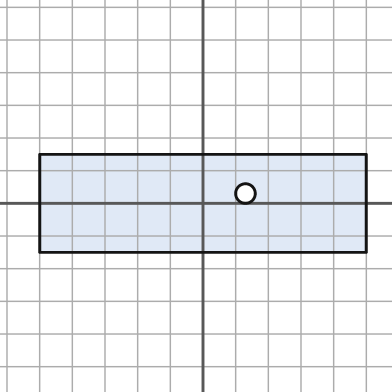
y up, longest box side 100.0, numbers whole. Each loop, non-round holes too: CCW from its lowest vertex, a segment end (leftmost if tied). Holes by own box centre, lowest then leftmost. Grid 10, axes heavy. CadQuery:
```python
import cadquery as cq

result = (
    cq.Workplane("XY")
    .moveTo(-50.0, -15.0)
    .lineTo(50.0, -15.0)
    .lineTo(50.0, 15.0)
    .lineTo(-50.0, 15.0)
    .close()
    .moveTo(13.0, 3.0)
    .circle(3.0)
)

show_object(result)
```